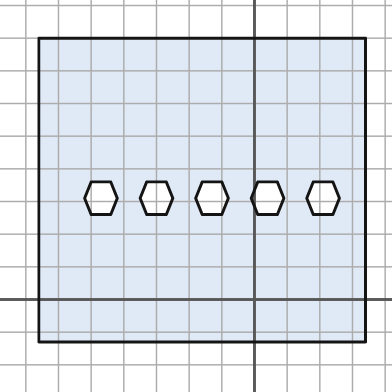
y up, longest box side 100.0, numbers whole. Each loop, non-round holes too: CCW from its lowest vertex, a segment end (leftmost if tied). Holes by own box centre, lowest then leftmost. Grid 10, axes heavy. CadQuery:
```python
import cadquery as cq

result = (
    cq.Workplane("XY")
    .moveTo(-66.0, -13.0)
    .lineTo(34.0, -13.0)
    .lineTo(34.0, 80.0)
    .lineTo(-66.0, 80.0)
    .close()
    .moveTo(-50.0, 26.0)
    .lineTo(-44.0, 26.0)
    .lineTo(-42.0, 31.0)
    .lineTo(-44.0, 36.0)
    .lineTo(-50.0, 36.0)
    .lineTo(-52.0, 31.0)
    .close()
    .moveTo(-33.0, 26.0)
    .lineTo(-27.0, 26.0)
    .lineTo(-25.0, 31.0)
    .lineTo(-27.0, 36.0)
    .lineTo(-33.0, 36.0)
    .lineTo(-35.0, 31.0)
    .close()
    .moveTo(-16.0, 26.0)
    .lineTo(-10.0, 26.0)
    .lineTo(-8.0, 31.0)
    .lineTo(-10.0, 36.0)
    .lineTo(-16.0, 36.0)
    .lineTo(-18.0, 31.0)
    .close()
    .moveTo(1.0, 26.0)
    .lineTo(7.0, 26.0)
    .lineTo(9.0, 31.0)
    .lineTo(7.0, 36.0)
    .lineTo(1.0, 36.0)
    .lineTo(-1.0, 31.0)
    .close()
    .moveTo(18.0, 26.0)
    .lineTo(24.0, 26.0)
    .lineTo(26.0, 31.0)
    .lineTo(24.0, 36.0)
    .lineTo(18.0, 36.0)
    .lineTo(16.0, 31.0)
    .close()
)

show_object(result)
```